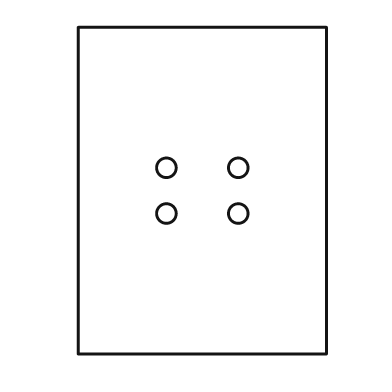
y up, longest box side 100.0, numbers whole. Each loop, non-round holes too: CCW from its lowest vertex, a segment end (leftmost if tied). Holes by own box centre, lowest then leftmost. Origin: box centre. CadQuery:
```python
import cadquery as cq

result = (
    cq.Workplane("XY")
    .moveTo(-38.0, -50.0)
    .lineTo(38.0, -50.0)
    .lineTo(38.0, 50.0)
    .lineTo(-38.0, 50.0)
    .close()
    .moveTo(-11.0, -7.0)
    .circle(3.0)
    .moveTo(11.0, -7.0)
    .circle(3.0)
    .moveTo(-11.0, 7.0)
    .circle(3.0)
    .moveTo(11.0, 7.0)
    .circle(3.0)
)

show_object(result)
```